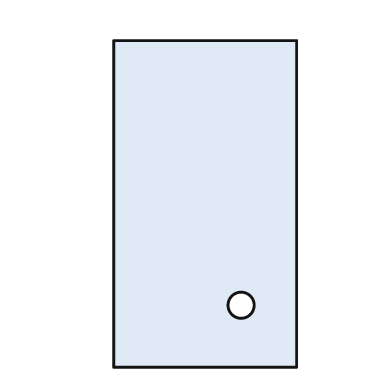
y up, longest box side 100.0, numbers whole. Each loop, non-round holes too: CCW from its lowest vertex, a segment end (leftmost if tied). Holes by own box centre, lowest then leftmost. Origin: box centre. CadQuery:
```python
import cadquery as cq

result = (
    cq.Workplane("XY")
    .moveTo(-28.0, -50.0)
    .lineTo(28.0, -50.0)
    .lineTo(28.0, 50.0)
    .lineTo(-28.0, 50.0)
    .close()
    .moveTo(11.0, -31.0)
    .circle(4.0)
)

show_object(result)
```